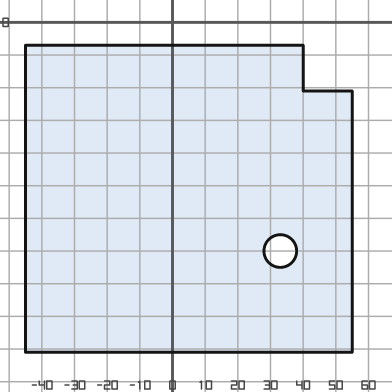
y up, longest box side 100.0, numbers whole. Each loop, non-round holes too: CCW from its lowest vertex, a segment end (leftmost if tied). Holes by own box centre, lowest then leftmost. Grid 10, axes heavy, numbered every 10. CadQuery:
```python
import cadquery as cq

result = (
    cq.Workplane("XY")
    .moveTo(-45.0, -101.0)
    .lineTo(55.0, -101.0)
    .lineTo(55.0, -21.0)
    .lineTo(40.0, -21.0)
    .lineTo(40.0, -7.0)
    .lineTo(-45.0, -7.0)
    .close()
    .moveTo(33.0, -70.0)
    .circle(5.0)
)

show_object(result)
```